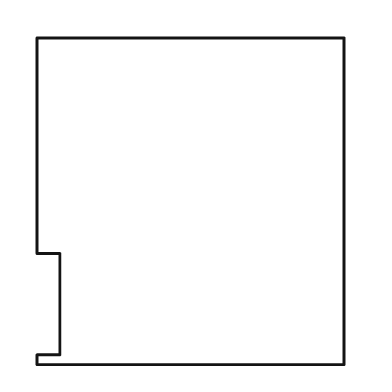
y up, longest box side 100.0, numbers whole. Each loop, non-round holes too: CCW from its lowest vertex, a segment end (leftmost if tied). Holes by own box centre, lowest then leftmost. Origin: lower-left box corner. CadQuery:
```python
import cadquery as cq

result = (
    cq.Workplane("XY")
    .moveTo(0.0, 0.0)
    .lineTo(94.0, 0.0)
    .lineTo(94.0, 100.0)
    .lineTo(0.0, 100.0)
    .lineTo(0.0, 34.0)
    .lineTo(7.0, 34.0)
    .lineTo(7.0, 3.0)
    .lineTo(0.0, 3.0)
    .close()
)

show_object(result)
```